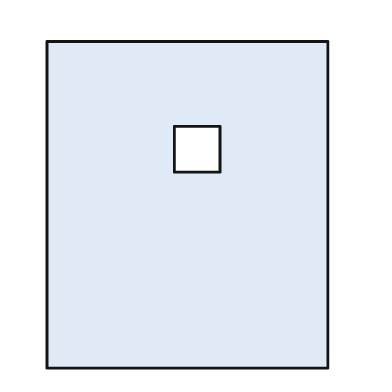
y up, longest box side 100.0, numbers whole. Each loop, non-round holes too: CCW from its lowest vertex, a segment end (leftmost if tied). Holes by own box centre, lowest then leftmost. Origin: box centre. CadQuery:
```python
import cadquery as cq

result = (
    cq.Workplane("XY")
    .moveTo(-43.0, -50.0)
    .lineTo(43.0, -50.0)
    .lineTo(43.0, 50.0)
    .lineTo(-43.0, 50.0)
    .close()
    .moveTo(-4.0, 10.0)
    .lineTo(10.0, 10.0)
    .lineTo(10.0, 24.0)
    .lineTo(-4.0, 24.0)
    .close()
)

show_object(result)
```